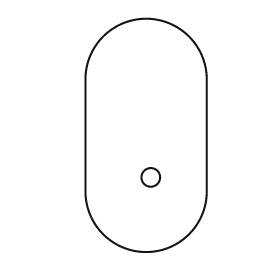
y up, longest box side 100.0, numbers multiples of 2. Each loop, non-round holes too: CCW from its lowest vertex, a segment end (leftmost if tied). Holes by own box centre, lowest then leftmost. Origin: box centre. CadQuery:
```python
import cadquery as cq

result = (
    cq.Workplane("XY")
    .moveTo(-26.0, -24.0)
    .threePointArc((0.0, -50.0), (26.0, -24.0))
    .lineTo(26.0, 24.0)
    .threePointArc((0.0, 50.0), (-26.0, 24.0))
    .close()
    .moveTo(2.0, -18.0)
    .circle(4.0)
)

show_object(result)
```